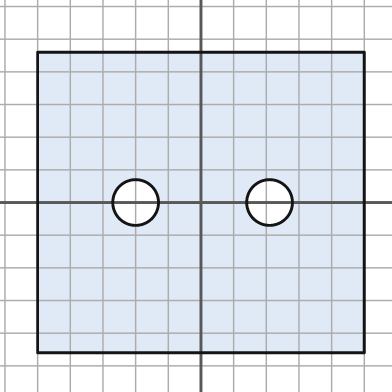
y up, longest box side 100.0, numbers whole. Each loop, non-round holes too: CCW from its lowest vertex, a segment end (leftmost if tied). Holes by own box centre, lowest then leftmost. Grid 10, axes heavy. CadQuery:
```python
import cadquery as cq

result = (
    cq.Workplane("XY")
    .moveTo(-50.0, -46.0)
    .lineTo(50.0, -46.0)
    .lineTo(50.0, 46.0)
    .lineTo(-50.0, 46.0)
    .close()
    .moveTo(-20.0, 0.0)
    .circle(7.0)
    .moveTo(21.0, 0.0)
    .circle(7.0)
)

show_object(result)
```